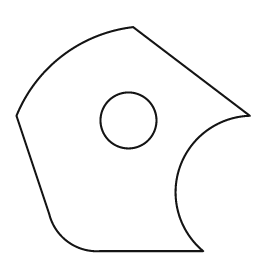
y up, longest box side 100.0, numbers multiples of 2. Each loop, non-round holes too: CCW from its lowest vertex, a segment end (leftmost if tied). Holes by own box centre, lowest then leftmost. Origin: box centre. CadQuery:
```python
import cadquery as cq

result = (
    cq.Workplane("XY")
    .moveTo(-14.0, -48.0)
    .lineTo(30.0, -48.0)
    .threePointArc((20.0, -12.0), (50.0, 10.0))
    .lineTo(0.0, 48.0)
    .threePointArc((-30.0, 36.0), (-50.0, 10.0))
    .lineTo(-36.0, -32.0)
    .threePointArc((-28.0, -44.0), (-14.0, -48.0))
    .close()
    .moveTo(-2.0, 8.0)
    .circle(12.0)
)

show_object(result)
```